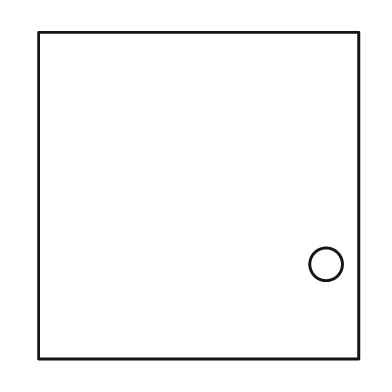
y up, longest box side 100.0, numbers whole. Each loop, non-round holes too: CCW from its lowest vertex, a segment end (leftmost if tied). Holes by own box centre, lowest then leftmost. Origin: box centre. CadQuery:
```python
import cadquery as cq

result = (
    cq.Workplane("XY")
    .moveTo(-49.0, -50.0)
    .lineTo(49.0, -50.0)
    .lineTo(49.0, 50.0)
    .lineTo(-49.0, 50.0)
    .close()
    .moveTo(39.0, -21.0)
    .circle(5.0)
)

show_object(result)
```